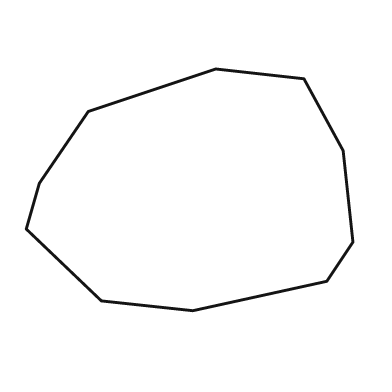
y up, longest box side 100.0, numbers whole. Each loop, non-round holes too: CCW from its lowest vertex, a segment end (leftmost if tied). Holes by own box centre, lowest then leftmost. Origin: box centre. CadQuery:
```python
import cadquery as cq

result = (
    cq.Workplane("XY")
    .moveTo(1.0, -37.0)
    .lineTo(42.0, -28.0)
    .lineTo(50.0, -16.0)
    .lineTo(47.0, 12.0)
    .lineTo(35.0, 34.0)
    .lineTo(8.0, 37.0)
    .lineTo(-31.0, 24.0)
    .lineTo(-46.0, 2.0)
    .lineTo(-50.0, -12.0)
    .lineTo(-27.0, -34.0)
    .close()
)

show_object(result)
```